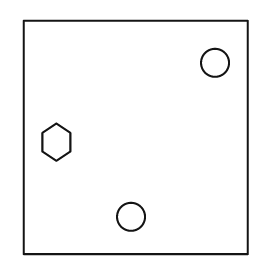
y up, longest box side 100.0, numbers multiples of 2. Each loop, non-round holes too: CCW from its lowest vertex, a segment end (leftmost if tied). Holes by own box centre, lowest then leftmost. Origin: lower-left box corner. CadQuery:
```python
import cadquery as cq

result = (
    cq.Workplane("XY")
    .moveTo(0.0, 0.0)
    .lineTo(96.0, 0.0)
    .lineTo(96.0, 100.0)
    .lineTo(0.0, 100.0)
    .close()
    .moveTo(46.0, 16.0)
    .circle(6.0)
    .moveTo(14.0, 40.0)
    .lineTo(20.0, 44.0)
    .lineTo(20.0, 52.0)
    .lineTo(14.0, 56.0)
    .lineTo(8.0, 52.0)
    .lineTo(8.0, 44.0)
    .close()
    .moveTo(82.0, 82.0)
    .circle(6.0)
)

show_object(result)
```